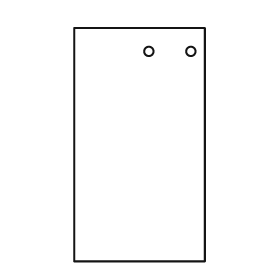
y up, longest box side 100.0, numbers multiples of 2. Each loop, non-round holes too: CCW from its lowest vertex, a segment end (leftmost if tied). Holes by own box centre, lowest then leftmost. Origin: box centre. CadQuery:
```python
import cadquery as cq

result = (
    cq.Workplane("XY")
    .moveTo(-28.0, -50.0)
    .lineTo(28.0, -50.0)
    .lineTo(28.0, 50.0)
    .lineTo(-28.0, 50.0)
    .close()
    .moveTo(4.0, 40.0)
    .circle(2.0)
    .moveTo(22.0, 40.0)
    .circle(2.0)
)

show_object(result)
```